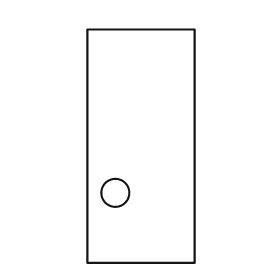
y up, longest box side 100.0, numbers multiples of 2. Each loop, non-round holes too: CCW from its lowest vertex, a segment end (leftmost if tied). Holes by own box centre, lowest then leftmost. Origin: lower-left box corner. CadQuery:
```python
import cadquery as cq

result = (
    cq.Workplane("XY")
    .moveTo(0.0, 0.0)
    .lineTo(46.0, 0.0)
    .lineTo(46.0, 100.0)
    .lineTo(0.0, 100.0)
    .close()
    .moveTo(12.0, 30.0)
    .circle(6.0)
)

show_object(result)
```